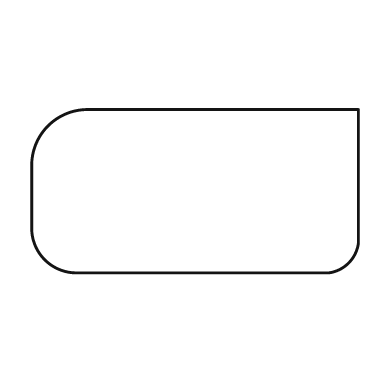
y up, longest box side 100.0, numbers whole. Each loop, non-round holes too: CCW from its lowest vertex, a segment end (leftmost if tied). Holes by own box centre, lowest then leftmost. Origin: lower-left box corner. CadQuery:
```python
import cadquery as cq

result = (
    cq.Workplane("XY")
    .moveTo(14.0, 0.0)
    .lineTo(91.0, 0.0)
    .threePointArc((97.0, 3.0), (100.0, 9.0))
    .lineTo(100.0, 50.0)
    .lineTo(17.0, 50.0)
    .threePointArc((5.0, 45.0), (0.0, 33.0))
    .lineTo(0.0, 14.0)
    .threePointArc((4.0, 4.0), (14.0, 0.0))
    .close()
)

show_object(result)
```